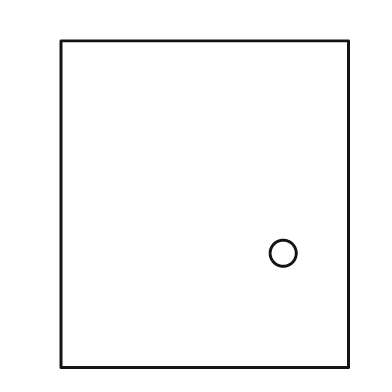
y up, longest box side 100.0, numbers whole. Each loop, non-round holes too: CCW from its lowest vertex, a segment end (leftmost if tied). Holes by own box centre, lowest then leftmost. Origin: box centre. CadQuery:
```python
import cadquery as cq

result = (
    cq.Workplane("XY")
    .moveTo(-44.0, -50.0)
    .lineTo(44.0, -50.0)
    .lineTo(44.0, 50.0)
    .lineTo(-44.0, 50.0)
    .close()
    .moveTo(24.0, -15.0)
    .circle(4.0)
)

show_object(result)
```